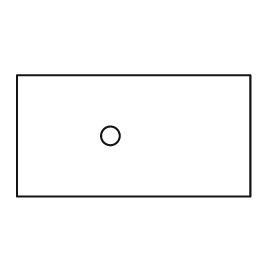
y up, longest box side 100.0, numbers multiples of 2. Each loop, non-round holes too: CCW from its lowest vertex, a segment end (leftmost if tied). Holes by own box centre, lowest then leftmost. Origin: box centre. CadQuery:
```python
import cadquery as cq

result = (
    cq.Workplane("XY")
    .moveTo(-50.0, -26.0)
    .lineTo(50.0, -26.0)
    .lineTo(50.0, 26.0)
    .lineTo(-50.0, 26.0)
    .close()
    .moveTo(-10.0, 0.0)
    .circle(4.0)
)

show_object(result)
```